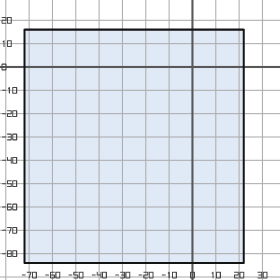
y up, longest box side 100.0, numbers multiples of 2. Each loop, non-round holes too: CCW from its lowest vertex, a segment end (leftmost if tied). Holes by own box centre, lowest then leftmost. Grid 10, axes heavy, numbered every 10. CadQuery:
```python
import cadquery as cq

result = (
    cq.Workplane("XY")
    .moveTo(-72.0, -84.0)
    .lineTo(22.0, -84.0)
    .lineTo(22.0, 16.0)
    .lineTo(-72.0, 16.0)
    .close()
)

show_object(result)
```